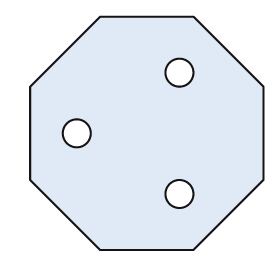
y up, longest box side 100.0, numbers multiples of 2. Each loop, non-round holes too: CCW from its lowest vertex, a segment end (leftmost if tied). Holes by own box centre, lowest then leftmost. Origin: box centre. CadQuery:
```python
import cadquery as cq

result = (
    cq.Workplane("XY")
    .moveTo(-20.0, -50.0)
    .lineTo(20.0, -50.0)
    .lineTo(50.0, -20.0)
    .lineTo(50.0, 20.0)
    .lineTo(20.0, 50.0)
    .lineTo(-20.0, 50.0)
    .lineTo(-50.0, 20.0)
    .lineTo(-50.0, -20.0)
    .close()
    .moveTo(14.0, -26.0)
    .circle(6.0)
    .moveTo(-30.0, 0.0)
    .circle(6.0)
    .moveTo(14.0, 26.0)
    .circle(6.0)
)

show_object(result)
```